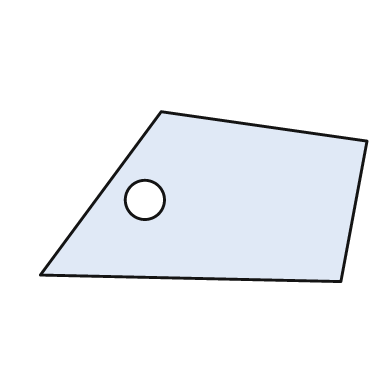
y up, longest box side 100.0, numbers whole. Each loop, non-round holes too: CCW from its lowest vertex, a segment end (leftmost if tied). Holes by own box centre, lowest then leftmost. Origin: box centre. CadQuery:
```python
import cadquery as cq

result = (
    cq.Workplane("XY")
    .moveTo(42.0, -26.0)
    .lineTo(50.0, 17.0)
    .lineTo(-13.0, 26.0)
    .lineTo(-50.0, -24.0)
    .close()
    .moveTo(-18.0, -1.0)
    .circle(6.0)
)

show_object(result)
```